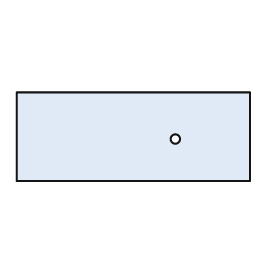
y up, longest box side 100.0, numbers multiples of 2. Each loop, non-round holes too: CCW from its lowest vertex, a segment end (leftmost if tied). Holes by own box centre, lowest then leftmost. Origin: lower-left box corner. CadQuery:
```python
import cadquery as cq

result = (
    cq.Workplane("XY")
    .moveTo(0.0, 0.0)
    .lineTo(100.0, 0.0)
    .lineTo(100.0, 38.0)
    .lineTo(0.0, 38.0)
    .close()
    .moveTo(68.0, 18.0)
    .circle(2.0)
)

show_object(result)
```